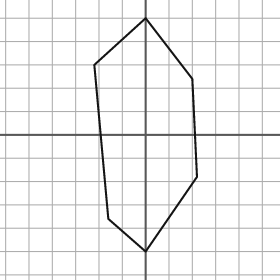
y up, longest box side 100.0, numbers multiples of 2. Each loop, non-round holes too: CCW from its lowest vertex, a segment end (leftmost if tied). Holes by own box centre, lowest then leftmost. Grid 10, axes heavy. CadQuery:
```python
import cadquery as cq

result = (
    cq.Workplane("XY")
    .moveTo(0.0, -50.0)
    .lineTo(22.0, -18.0)
    .lineTo(20.0, 24.0)
    .lineTo(0.0, 50.0)
    .lineTo(-22.0, 30.0)
    .lineTo(-16.0, -36.0)
    .close()
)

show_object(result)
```